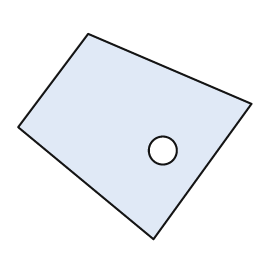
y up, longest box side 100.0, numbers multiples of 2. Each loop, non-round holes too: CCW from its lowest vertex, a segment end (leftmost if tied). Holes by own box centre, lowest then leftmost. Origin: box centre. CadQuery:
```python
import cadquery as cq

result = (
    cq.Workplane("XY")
    .moveTo(8.0, -44.0)
    .lineTo(50.0, 14.0)
    .lineTo(-20.0, 44.0)
    .lineTo(-50.0, 4.0)
    .close()
    .moveTo(12.0, -6.0)
    .circle(6.0)
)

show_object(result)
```